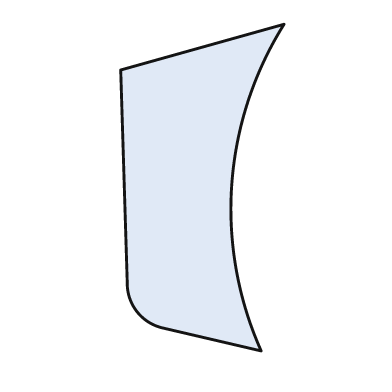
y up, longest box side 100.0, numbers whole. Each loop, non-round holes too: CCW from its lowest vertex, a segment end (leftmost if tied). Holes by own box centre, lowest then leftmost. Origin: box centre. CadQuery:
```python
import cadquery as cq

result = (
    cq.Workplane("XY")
    .moveTo(18.0, -50.0)
    .threePointArc((9.0, 1.0), (25.0, 50.0))
    .lineTo(-25.0, 36.0)
    .lineTo(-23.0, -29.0)
    .threePointArc((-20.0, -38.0), (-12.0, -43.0))
    .close()
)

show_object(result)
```